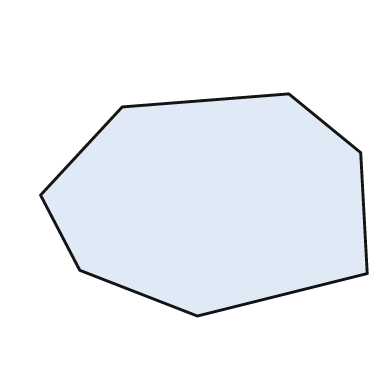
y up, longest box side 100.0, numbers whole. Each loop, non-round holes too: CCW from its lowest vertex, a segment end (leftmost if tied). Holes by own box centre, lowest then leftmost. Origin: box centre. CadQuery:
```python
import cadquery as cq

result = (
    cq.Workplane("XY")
    .moveTo(-2.0, -34.0)
    .lineTo(50.0, -21.0)
    .lineTo(48.0, 16.0)
    .lineTo(26.0, 34.0)
    .lineTo(-25.0, 30.0)
    .lineTo(-50.0, 3.0)
    .lineTo(-38.0, -20.0)
    .close()
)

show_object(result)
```